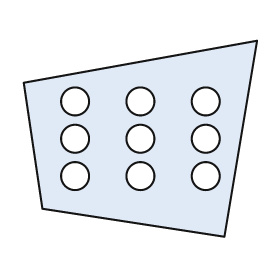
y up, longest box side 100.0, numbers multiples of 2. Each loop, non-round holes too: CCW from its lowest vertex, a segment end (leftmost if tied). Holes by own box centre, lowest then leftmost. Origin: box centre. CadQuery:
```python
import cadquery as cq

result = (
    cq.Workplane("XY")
    .moveTo(36.0, -42.0)
    .lineTo(50.0, 42.0)
    .lineTo(-50.0, 24.0)
    .lineTo(-42.0, -30.0)
    .close()
    .moveTo(-28.0, -16.0)
    .circle(6.0)
    .moveTo(0.0, -16.0)
    .circle(6.0)
    .moveTo(28.0, -16.0)
    .circle(6.0)
    .moveTo(-28.0, 0.0)
    .circle(6.0)
    .moveTo(0.0, 0.0)
    .circle(6.0)
    .moveTo(28.0, 0.0)
    .circle(6.0)
    .moveTo(-28.0, 16.0)
    .circle(6.0)
    .moveTo(0.0, 16.0)
    .circle(6.0)
    .moveTo(28.0, 16.0)
    .circle(6.0)
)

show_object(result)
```